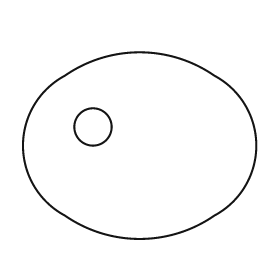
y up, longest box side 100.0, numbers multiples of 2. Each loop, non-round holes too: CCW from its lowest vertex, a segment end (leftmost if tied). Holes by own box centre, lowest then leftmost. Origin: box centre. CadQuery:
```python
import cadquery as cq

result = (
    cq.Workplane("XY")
    .moveTo(-32.0, -30.0)
    .threePointArc((0.0, -40.0), (32.0, -30.0))
    .threePointArc((50.0, 0.0), (32.0, 30.0))
    .threePointArc((0.0, 40.0), (-32.0, 30.0))
    .threePointArc((-50.0, 0.0), (-32.0, -30.0))
    .close()
    .moveTo(-20.0, 8.0)
    .circle(8.0)
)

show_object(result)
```